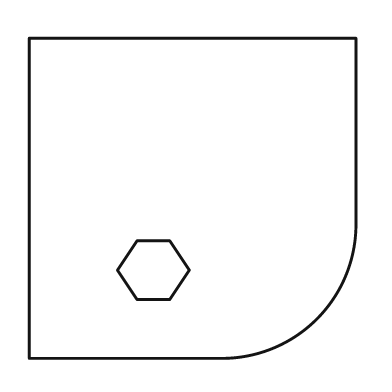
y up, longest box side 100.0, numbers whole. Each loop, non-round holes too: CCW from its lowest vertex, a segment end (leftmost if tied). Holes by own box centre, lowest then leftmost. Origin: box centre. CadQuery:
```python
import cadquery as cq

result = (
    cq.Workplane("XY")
    .moveTo(-50.0, -49.0)
    .lineTo(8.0, -49.0)
    .threePointArc((38.0, -37.0), (50.0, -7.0))
    .lineTo(50.0, 49.0)
    .lineTo(-50.0, 49.0)
    .close()
    .moveTo(-17.0, -31.0)
    .lineTo(-7.0, -31.0)
    .lineTo(-1.0, -22.0)
    .lineTo(-7.0, -13.0)
    .lineTo(-17.0, -13.0)
    .lineTo(-23.0, -22.0)
    .close()
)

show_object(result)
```